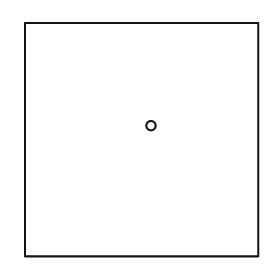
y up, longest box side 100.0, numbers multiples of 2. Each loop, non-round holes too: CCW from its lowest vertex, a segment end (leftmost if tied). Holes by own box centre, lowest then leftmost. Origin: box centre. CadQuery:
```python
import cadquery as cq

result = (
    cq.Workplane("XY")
    .moveTo(-50.0, -50.0)
    .lineTo(50.0, -50.0)
    .lineTo(50.0, 50.0)
    .lineTo(-50.0, 50.0)
    .close()
    .moveTo(4.0, 6.0)
    .circle(2.0)
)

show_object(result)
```